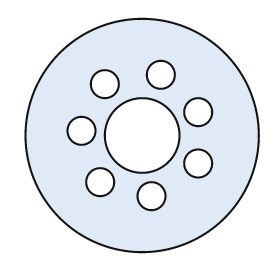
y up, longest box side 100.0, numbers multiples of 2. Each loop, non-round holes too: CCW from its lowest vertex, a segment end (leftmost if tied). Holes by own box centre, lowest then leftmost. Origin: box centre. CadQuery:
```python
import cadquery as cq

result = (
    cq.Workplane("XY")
    .moveTo(0.0, 0.0)
    .circle(50.0)
    .moveTo(4.0, -26.0)
    .circle(6.0)
    .moveTo(-18.0, -20.0)
    .circle(6.0)
    .moveTo(24.0, -12.0)
    .circle(6.0)
    .moveTo(0.0, 0.0)
    .circle(16.0)
    .moveTo(-26.0, 2.0)
    .circle(6.0)
    .moveTo(24.0, 10.0)
    .circle(6.0)
    .moveTo(-16.0, 22.0)
    .circle(6.0)
    .moveTo(8.0, 26.0)
    .circle(6.0)
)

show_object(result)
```